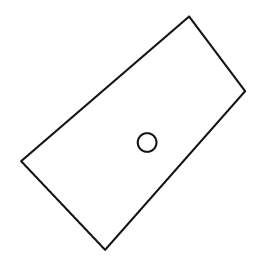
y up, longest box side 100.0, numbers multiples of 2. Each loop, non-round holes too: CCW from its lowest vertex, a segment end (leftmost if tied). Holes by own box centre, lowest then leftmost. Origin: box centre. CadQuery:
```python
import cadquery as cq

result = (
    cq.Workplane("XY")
    .moveTo(-12.0, -50.0)
    .lineTo(48.0, 18.0)
    .lineTo(24.0, 50.0)
    .lineTo(-48.0, -12.0)
    .close()
    .moveTo(6.0, -4.0)
    .circle(4.0)
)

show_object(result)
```